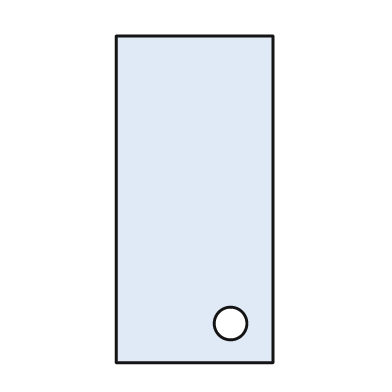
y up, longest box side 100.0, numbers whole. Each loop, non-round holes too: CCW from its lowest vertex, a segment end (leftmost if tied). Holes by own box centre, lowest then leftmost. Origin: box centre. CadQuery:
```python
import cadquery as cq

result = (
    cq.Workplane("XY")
    .moveTo(-24.0, -50.0)
    .lineTo(24.0, -50.0)
    .lineTo(24.0, 50.0)
    .lineTo(-24.0, 50.0)
    .close()
    .moveTo(11.0, -38.0)
    .circle(5.0)
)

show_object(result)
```